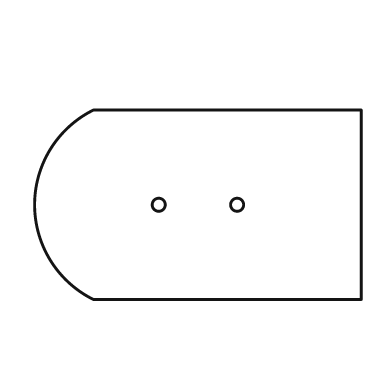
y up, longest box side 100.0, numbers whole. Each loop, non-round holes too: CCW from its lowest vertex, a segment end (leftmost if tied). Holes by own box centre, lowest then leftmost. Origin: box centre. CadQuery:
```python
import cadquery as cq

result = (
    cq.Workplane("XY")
    .moveTo(-32.0, -29.0)
    .lineTo(50.0, -29.0)
    .lineTo(50.0, 29.0)
    .lineTo(-32.0, 29.0)
    .threePointArc((-50.0, 0.0), (-32.0, -29.0))
    .close()
    .moveTo(-12.0, 0.0)
    .circle(2.0)
    .moveTo(12.0, 0.0)
    .circle(2.0)
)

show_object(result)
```